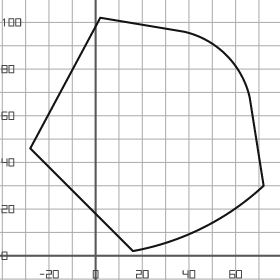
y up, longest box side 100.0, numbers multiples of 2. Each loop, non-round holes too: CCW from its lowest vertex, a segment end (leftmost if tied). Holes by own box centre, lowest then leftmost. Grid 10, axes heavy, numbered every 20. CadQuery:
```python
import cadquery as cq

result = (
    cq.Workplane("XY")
    .moveTo(16.0, 2.0)
    .threePointArc((46.0, 12.0), (72.0, 30.0))
    .lineTo(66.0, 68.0)
    .threePointArc((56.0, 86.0), (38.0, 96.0))
    .lineTo(2.0, 102.0)
    .lineTo(-28.0, 46.0)
    .close()
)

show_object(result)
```